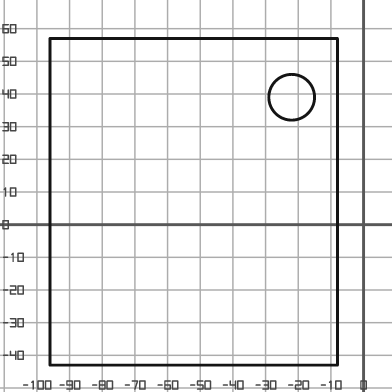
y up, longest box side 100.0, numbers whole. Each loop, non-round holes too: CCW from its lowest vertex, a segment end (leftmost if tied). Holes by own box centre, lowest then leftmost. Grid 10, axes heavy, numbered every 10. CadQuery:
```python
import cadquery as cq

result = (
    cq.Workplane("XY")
    .moveTo(-96.0, -43.0)
    .lineTo(-8.0, -43.0)
    .lineTo(-8.0, 57.0)
    .lineTo(-96.0, 57.0)
    .close()
    .moveTo(-22.0, 39.0)
    .circle(7.0)
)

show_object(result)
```